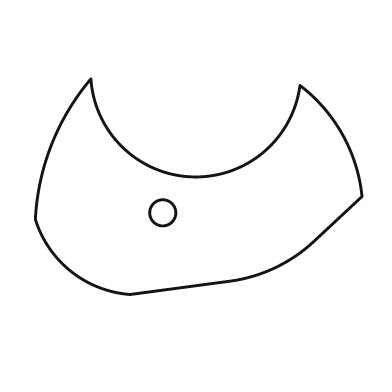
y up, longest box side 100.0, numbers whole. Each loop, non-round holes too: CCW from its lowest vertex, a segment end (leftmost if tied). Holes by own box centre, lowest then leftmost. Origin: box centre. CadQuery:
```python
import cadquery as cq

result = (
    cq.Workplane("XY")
    .moveTo(-21.0, -33.0)
    .lineTo(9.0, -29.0)
    .threePointArc((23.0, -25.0), (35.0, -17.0))
    .lineTo(50.0, -3.0)
    .threePointArc((44.0, 16.0), (31.0, 31.0))
    .threePointArc((-2.0, 3.0), (-33.0, 33.0))
    .threePointArc((-45.0, 13.0), (-50.0, -10.0))
    .threePointArc((-39.0, -26.0), (-21.0, -33.0))
    .close()
    .moveTo(-11.0, -8.0)
    .circle(4.0)
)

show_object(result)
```